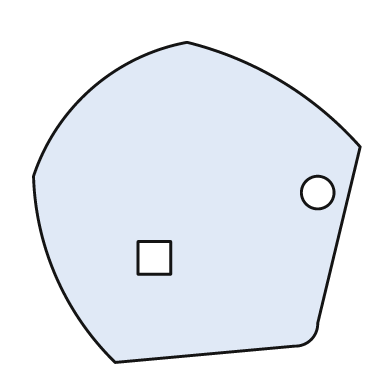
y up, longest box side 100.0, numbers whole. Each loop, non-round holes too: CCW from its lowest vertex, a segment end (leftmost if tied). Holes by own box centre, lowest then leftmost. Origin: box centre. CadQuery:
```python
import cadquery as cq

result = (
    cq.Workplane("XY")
    .moveTo(-25.0, -49.0)
    .lineTo(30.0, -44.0)
    .threePointArc((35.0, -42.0), (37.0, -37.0))
    .lineTo(50.0, 17.0)
    .threePointArc((26.0, 37.0), (-3.0, 49.0))
    .threePointArc((-32.0, 35.0), (-50.0, 8.0))
    .threePointArc((-43.0, -23.0), (-25.0, -49.0))
    .close()
    .moveTo(-18.0, -22.0)
    .lineTo(-8.0, -22.0)
    .lineTo(-8.0, -12.0)
    .lineTo(-18.0, -12.0)
    .close()
    .moveTo(37.0, 3.0)
    .circle(5.0)
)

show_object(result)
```